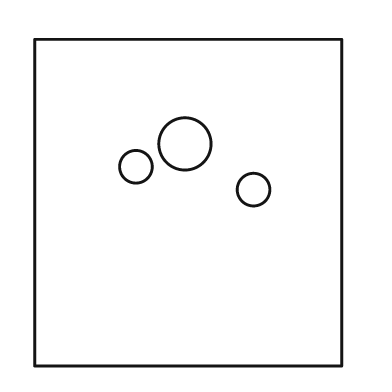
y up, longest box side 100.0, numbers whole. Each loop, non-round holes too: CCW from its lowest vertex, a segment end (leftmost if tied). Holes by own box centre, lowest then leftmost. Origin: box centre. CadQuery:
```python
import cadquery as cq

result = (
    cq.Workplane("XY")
    .moveTo(-47.0, -50.0)
    .lineTo(47.0, -50.0)
    .lineTo(47.0, 50.0)
    .lineTo(-47.0, 50.0)
    .close()
    .moveTo(20.0, 4.0)
    .circle(5.0)
    .moveTo(-16.0, 11.0)
    .circle(5.0)
    .moveTo(-1.0, 18.0)
    .circle(8.0)
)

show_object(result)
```